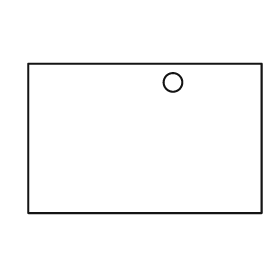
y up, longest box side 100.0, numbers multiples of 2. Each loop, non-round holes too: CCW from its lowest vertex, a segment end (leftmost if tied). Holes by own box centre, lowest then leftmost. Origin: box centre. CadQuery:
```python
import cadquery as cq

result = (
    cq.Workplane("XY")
    .moveTo(-50.0, -32.0)
    .lineTo(50.0, -32.0)
    .lineTo(50.0, 32.0)
    .lineTo(-50.0, 32.0)
    .close()
    .moveTo(12.0, 24.0)
    .circle(4.0)
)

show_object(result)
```